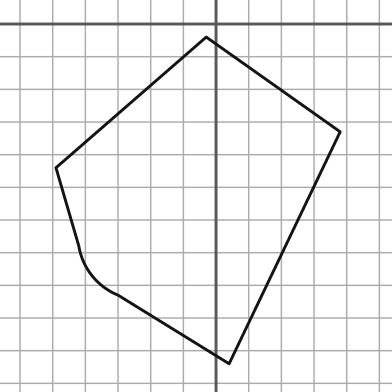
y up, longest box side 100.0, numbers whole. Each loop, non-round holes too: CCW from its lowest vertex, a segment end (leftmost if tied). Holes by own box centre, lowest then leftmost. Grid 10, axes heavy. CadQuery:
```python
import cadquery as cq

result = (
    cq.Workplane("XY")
    .moveTo(4.0, -104.0)
    .lineTo(38.0, -33.0)
    .lineTo(-3.0, -4.0)
    .lineTo(-49.0, -44.0)
    .lineTo(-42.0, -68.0)
    .threePointArc((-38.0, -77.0), (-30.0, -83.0))
    .close()
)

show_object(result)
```